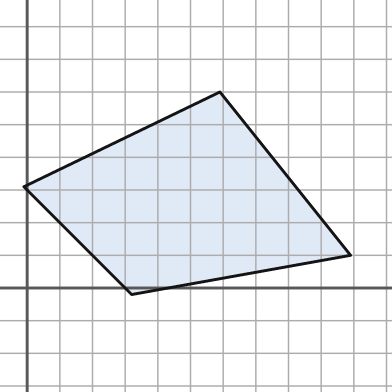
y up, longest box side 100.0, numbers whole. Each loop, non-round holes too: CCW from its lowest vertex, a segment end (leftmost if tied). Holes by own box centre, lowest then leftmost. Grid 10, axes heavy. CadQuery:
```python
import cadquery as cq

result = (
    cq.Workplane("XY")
    .moveTo(32.0, -2.0)
    .lineTo(99.0, 10.0)
    .lineTo(59.0, 60.0)
    .lineTo(-1.0, 31.0)
    .close()
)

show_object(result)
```